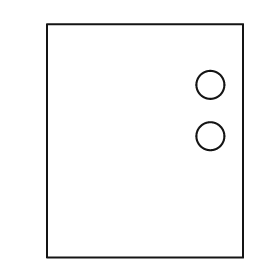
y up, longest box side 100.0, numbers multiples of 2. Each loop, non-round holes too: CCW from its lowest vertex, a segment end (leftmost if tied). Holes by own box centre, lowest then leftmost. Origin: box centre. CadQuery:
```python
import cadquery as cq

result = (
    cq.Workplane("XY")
    .moveTo(-42.0, -50.0)
    .lineTo(42.0, -50.0)
    .lineTo(42.0, 50.0)
    .lineTo(-42.0, 50.0)
    .close()
    .moveTo(28.0, 2.0)
    .circle(6.0)
    .moveTo(28.0, 24.0)
    .circle(6.0)
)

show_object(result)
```